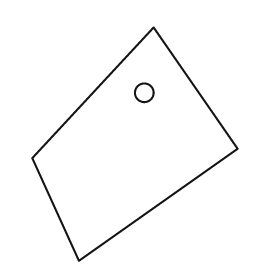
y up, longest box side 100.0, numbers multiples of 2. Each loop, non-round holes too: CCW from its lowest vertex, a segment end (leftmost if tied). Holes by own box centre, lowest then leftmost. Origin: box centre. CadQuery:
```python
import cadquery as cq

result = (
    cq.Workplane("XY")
    .moveTo(-24.0, -50.0)
    .lineTo(44.0, -2.0)
    .lineTo(8.0, 50.0)
    .lineTo(-44.0, -6.0)
    .close()
    .moveTo(4.0, 22.0)
    .circle(4.0)
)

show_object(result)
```